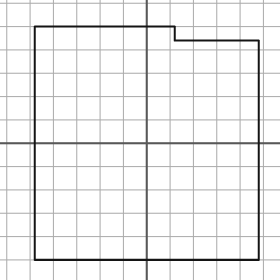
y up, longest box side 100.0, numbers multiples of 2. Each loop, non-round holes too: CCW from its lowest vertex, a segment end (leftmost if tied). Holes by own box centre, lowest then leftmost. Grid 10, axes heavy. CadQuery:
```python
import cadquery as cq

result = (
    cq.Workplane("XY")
    .moveTo(-48.0, -50.0)
    .lineTo(48.0, -50.0)
    .lineTo(48.0, 44.0)
    .lineTo(12.0, 44.0)
    .lineTo(12.0, 50.0)
    .lineTo(-48.0, 50.0)
    .close()
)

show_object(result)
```